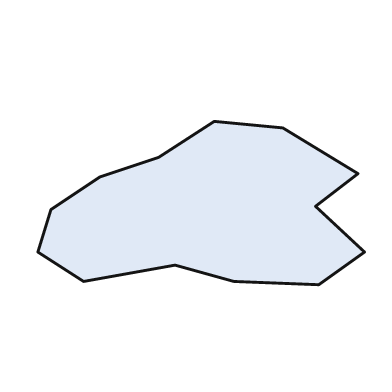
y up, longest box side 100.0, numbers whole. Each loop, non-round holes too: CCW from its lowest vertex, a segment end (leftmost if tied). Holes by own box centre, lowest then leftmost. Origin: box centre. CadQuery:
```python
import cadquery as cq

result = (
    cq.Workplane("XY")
    .moveTo(36.0, -25.0)
    .lineTo(50.0, -15.0)
    .lineTo(35.0, -1.0)
    .lineTo(48.0, 9.0)
    .lineTo(25.0, 23.0)
    .lineTo(4.0, 25.0)
    .lineTo(-13.0, 14.0)
    .lineTo(-31.0, 8.0)
    .lineTo(-46.0, -2.0)
    .lineTo(-50.0, -15.0)
    .lineTo(-36.0, -24.0)
    .lineTo(-8.0, -19.0)
    .lineTo(10.0, -24.0)
    .close()
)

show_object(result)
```